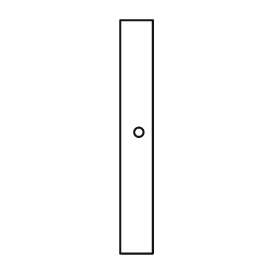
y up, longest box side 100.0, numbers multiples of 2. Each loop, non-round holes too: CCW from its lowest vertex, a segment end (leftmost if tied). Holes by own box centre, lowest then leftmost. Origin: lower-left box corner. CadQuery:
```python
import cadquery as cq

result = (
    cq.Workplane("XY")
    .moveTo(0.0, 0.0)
    .lineTo(14.0, 0.0)
    .lineTo(14.0, 100.0)
    .lineTo(0.0, 100.0)
    .close()
    .moveTo(8.0, 52.0)
    .circle(2.0)
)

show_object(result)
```